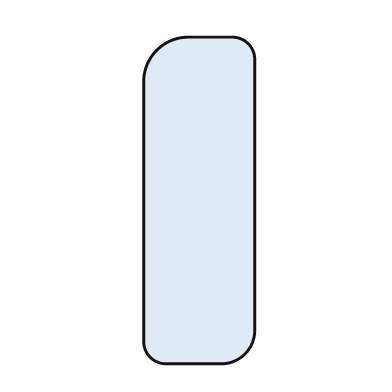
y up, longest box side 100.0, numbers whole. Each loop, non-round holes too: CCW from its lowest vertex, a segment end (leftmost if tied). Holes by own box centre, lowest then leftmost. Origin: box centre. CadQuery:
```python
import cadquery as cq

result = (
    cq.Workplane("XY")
    .moveTo(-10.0, -50.0)
    .lineTo(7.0, -50.0)
    .threePointArc((14.0, -47.0), (17.0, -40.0))
    .lineTo(17.0, 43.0)
    .threePointArc((15.0, 48.0), (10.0, 50.0))
    .lineTo(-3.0, 50.0)
    .threePointArc((-13.0, 46.0), (-17.0, 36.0))
    .lineTo(-17.0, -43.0)
    .threePointArc((-15.0, -48.0), (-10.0, -50.0))
    .close()
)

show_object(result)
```